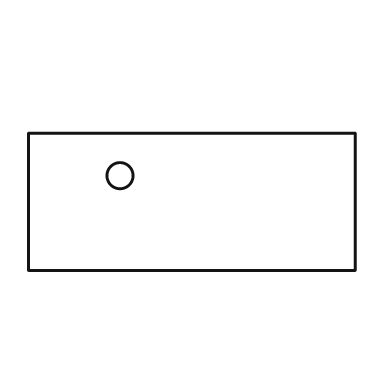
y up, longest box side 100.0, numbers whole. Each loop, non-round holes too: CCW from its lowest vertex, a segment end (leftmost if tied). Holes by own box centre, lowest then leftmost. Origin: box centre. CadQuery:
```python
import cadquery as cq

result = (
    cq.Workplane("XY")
    .moveTo(-50.0, -21.0)
    .lineTo(50.0, -21.0)
    .lineTo(50.0, 21.0)
    .lineTo(-50.0, 21.0)
    .close()
    .moveTo(-22.0, 8.0)
    .circle(4.0)
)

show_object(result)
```